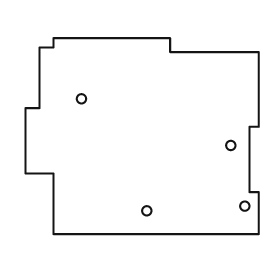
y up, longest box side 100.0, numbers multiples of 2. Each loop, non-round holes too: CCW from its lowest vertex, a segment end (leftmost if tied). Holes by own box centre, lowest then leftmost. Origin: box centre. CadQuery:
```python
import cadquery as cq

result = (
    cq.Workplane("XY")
    .moveTo(-38.0, -42.0)
    .lineTo(50.0, -42.0)
    .lineTo(50.0, -24.0)
    .lineTo(46.0, -24.0)
    .lineTo(46.0, 4.0)
    .lineTo(50.0, 4.0)
    .lineTo(50.0, 36.0)
    .lineTo(12.0, 36.0)
    .lineTo(12.0, 42.0)
    .lineTo(-38.0, 42.0)
    .lineTo(-38.0, 38.0)
    .lineTo(-44.0, 38.0)
    .lineTo(-44.0, 12.0)
    .lineTo(-50.0, 12.0)
    .lineTo(-50.0, -16.0)
    .lineTo(-38.0, -16.0)
    .close()
    .moveTo(2.0, -32.0)
    .circle(2.0)
    .moveTo(44.0, -30.0)
    .circle(2.0)
    .moveTo(38.0, -4.0)
    .circle(2.0)
    .moveTo(-26.0, 16.0)
    .circle(2.0)
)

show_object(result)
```